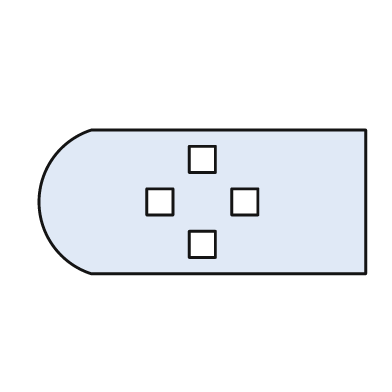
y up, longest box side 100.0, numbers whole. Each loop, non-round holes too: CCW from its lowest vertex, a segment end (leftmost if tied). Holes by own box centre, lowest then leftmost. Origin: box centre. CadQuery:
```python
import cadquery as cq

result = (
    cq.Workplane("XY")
    .moveTo(-34.0, -22.0)
    .lineTo(50.0, -22.0)
    .lineTo(50.0, 22.0)
    .lineTo(-34.0, 22.0)
    .threePointArc((-50.0, 0.0), (-34.0, -22.0))
    .close()
    .moveTo(-4.0, -17.0)
    .lineTo(4.0, -17.0)
    .lineTo(4.0, -9.0)
    .lineTo(-4.0, -9.0)
    .close()
    .moveTo(-17.0, -4.0)
    .lineTo(-9.0, -4.0)
    .lineTo(-9.0, 4.0)
    .lineTo(-17.0, 4.0)
    .close()
    .moveTo(9.0, -4.0)
    .lineTo(17.0, -4.0)
    .lineTo(17.0, 4.0)
    .lineTo(9.0, 4.0)
    .close()
    .moveTo(-4.0, 9.0)
    .lineTo(4.0, 9.0)
    .lineTo(4.0, 17.0)
    .lineTo(-4.0, 17.0)
    .close()
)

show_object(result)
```